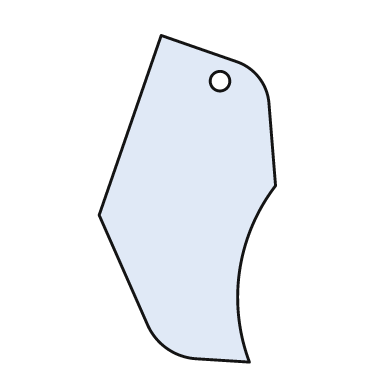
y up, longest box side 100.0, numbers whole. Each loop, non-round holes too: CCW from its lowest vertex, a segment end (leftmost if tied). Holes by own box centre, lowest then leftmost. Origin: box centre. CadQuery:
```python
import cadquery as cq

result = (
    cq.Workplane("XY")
    .moveTo(19.0, -50.0)
    .threePointArc((16.0, -22.0), (27.0, 4.0))
    .lineTo(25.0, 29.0)
    .threePointArc((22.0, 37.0), (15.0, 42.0))
    .lineTo(-8.0, 50.0)
    .lineTo(-27.0, -5.0)
    .lineTo(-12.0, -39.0)
    .threePointArc((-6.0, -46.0), (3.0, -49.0))
    .close()
    .moveTo(10.0, 36.0)
    .circle(3.0)
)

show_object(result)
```